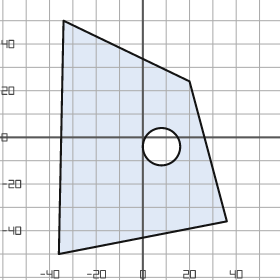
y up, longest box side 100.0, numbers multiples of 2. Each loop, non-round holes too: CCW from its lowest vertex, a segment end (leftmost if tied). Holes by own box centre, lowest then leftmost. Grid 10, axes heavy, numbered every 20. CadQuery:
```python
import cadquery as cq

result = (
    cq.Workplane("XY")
    .moveTo(-36.0, -50.0)
    .lineTo(36.0, -36.0)
    .lineTo(20.0, 24.0)
    .lineTo(-34.0, 50.0)
    .close()
    .moveTo(8.0, -4.0)
    .circle(8.0)
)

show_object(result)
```